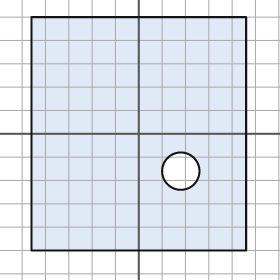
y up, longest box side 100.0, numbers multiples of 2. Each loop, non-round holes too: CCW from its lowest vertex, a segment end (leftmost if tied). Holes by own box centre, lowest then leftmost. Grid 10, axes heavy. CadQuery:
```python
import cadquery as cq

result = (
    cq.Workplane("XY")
    .moveTo(-46.0, -50.0)
    .lineTo(46.0, -50.0)
    .lineTo(46.0, 50.0)
    .lineTo(-46.0, 50.0)
    .close()
    .moveTo(18.0, -16.0)
    .circle(8.0)
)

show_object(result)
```